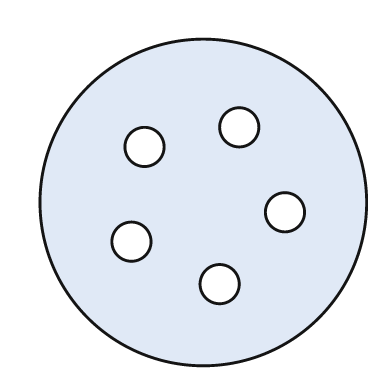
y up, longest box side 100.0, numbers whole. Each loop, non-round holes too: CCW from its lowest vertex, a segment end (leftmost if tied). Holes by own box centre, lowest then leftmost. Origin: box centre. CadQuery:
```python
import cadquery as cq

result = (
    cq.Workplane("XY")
    .moveTo(0.0, 0.0)
    .circle(50.0)
    .moveTo(5.0, -25.0)
    .circle(6.0)
    .moveTo(-22.0, -12.0)
    .circle(6.0)
    .moveTo(25.0, -3.0)
    .circle(6.0)
    .moveTo(-18.0, 17.0)
    .circle(6.0)
    .moveTo(11.0, 23.0)
    .circle(6.0)
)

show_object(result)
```